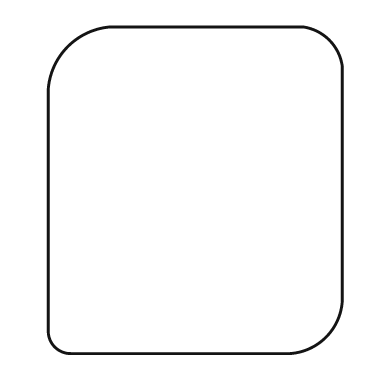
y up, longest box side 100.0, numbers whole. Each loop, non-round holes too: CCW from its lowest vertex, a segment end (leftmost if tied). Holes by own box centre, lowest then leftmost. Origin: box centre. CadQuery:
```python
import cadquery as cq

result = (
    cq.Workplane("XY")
    .moveTo(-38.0, -50.0)
    .lineTo(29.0, -50.0)
    .threePointArc((40.0, -45.0), (45.0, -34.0))
    .lineTo(45.0, 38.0)
    .threePointArc((41.0, 46.0), (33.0, 50.0))
    .lineTo(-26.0, 50.0)
    .threePointArc((-39.0, 44.0), (-45.0, 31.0))
    .lineTo(-45.0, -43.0)
    .threePointArc((-43.0, -48.0), (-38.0, -50.0))
    .close()
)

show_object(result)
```